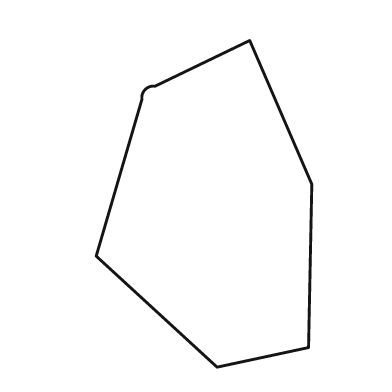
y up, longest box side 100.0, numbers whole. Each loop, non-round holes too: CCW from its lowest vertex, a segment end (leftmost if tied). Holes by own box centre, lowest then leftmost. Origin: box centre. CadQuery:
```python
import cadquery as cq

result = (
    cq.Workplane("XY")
    .moveTo(4.0, -50.0)
    .lineTo(32.0, -44.0)
    .lineTo(33.0, 6.0)
    .lineTo(14.0, 50.0)
    .lineTo(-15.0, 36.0)
    .threePointArc((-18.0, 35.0), (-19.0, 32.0))
    .lineTo(-33.0, -16.0)
    .close()
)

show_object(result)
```